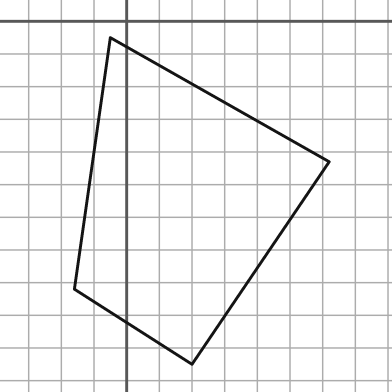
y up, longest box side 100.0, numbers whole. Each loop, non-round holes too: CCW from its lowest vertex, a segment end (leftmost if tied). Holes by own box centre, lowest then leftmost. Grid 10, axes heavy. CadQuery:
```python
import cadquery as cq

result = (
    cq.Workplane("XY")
    .moveTo(20.0, -105.0)
    .lineTo(62.0, -43.0)
    .lineTo(-5.0, -5.0)
    .lineTo(-16.0, -82.0)
    .close()
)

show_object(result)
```